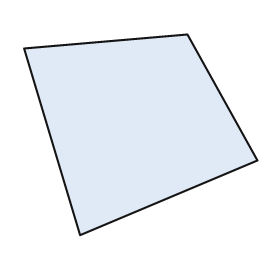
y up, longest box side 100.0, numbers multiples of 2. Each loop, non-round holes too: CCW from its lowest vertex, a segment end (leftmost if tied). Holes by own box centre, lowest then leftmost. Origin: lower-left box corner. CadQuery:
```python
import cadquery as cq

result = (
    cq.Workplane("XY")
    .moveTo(24.0, 0.0)
    .lineTo(100.0, 32.0)
    .lineTo(70.0, 86.0)
    .lineTo(0.0, 80.0)
    .close()
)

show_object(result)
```